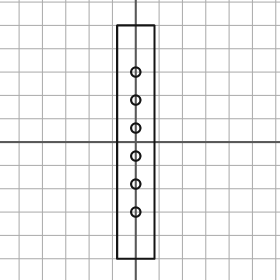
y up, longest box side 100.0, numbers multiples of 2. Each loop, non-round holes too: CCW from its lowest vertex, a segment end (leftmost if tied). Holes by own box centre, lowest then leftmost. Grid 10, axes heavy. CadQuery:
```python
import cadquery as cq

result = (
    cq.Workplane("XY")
    .moveTo(-8.0, -50.0)
    .lineTo(8.0, -50.0)
    .lineTo(8.0, 50.0)
    .lineTo(-8.0, 50.0)
    .close()
    .moveTo(0.0, -30.0)
    .circle(2.0)
    .moveTo(0.0, -18.0)
    .circle(2.0)
    .moveTo(0.0, -6.0)
    .circle(2.0)
    .moveTo(0.0, 6.0)
    .circle(2.0)
    .moveTo(0.0, 18.0)
    .circle(2.0)
    .moveTo(0.0, 30.0)
    .circle(2.0)
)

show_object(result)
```